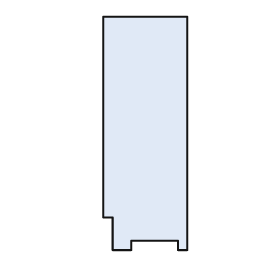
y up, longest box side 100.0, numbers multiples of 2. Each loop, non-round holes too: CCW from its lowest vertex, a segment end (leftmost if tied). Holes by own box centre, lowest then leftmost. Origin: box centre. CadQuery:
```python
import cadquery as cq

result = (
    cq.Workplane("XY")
    .moveTo(-14.0, -50.0)
    .lineTo(-6.0, -50.0)
    .lineTo(-6.0, -46.0)
    .lineTo(14.0, -46.0)
    .lineTo(14.0, -50.0)
    .lineTo(18.0, -50.0)
    .lineTo(18.0, 50.0)
    .lineTo(-18.0, 50.0)
    .lineTo(-18.0, -36.0)
    .lineTo(-14.0, -36.0)
    .close()
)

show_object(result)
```